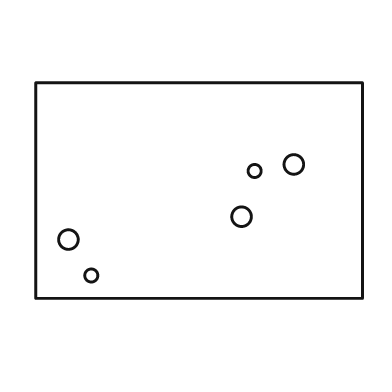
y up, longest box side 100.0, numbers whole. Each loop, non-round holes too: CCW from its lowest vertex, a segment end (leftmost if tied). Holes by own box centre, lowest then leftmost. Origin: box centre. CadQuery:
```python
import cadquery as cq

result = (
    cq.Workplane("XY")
    .moveTo(-50.0, -33.0)
    .lineTo(50.0, -33.0)
    .lineTo(50.0, 33.0)
    .lineTo(-50.0, 33.0)
    .close()
    .moveTo(-33.0, -26.0)
    .circle(2.0)
    .moveTo(-40.0, -15.0)
    .circle(3.0)
    .moveTo(13.0, -8.0)
    .circle(3.0)
    .moveTo(17.0, 6.0)
    .circle(2.0)
    .moveTo(29.0, 8.0)
    .circle(3.0)
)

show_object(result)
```